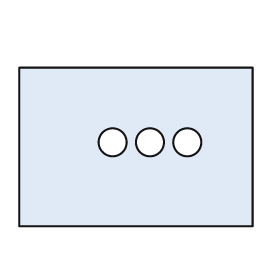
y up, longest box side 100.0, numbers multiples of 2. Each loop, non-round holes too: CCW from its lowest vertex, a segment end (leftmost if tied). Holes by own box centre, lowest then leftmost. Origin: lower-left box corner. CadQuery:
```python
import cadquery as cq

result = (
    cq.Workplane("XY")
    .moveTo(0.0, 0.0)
    .lineTo(100.0, 0.0)
    .lineTo(100.0, 68.0)
    .lineTo(0.0, 68.0)
    .close()
    .moveTo(40.0, 36.0)
    .circle(6.0)
    .moveTo(56.0, 36.0)
    .circle(6.0)
    .moveTo(72.0, 36.0)
    .circle(6.0)
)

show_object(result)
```